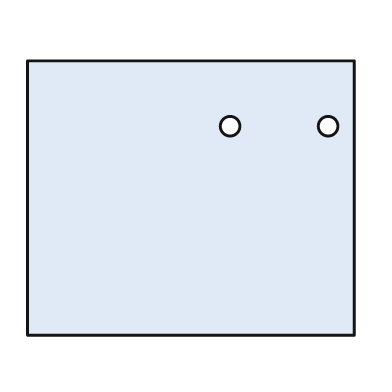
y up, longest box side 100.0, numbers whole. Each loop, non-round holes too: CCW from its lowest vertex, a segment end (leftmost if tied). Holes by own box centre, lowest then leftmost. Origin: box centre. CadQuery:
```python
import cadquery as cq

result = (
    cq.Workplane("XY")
    .moveTo(-50.0, -42.0)
    .lineTo(50.0, -42.0)
    .lineTo(50.0, 42.0)
    .lineTo(-50.0, 42.0)
    .close()
    .moveTo(12.0, 22.0)
    .circle(3.0)
    .moveTo(42.0, 22.0)
    .circle(3.0)
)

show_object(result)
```